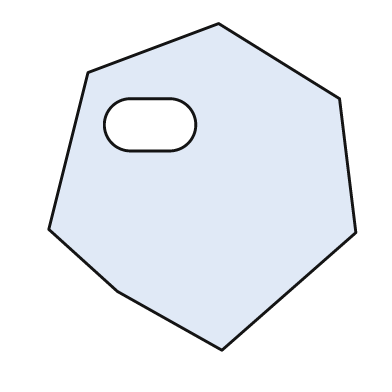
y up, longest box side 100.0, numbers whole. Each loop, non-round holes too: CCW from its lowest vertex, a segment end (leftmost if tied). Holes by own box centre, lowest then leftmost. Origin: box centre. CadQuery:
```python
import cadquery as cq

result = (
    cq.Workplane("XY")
    .moveTo(6.0, -50.0)
    .lineTo(47.0, -14.0)
    .lineTo(42.0, 27.0)
    .lineTo(5.0, 50.0)
    .lineTo(-35.0, 35.0)
    .lineTo(-47.0, -13.0)
    .lineTo(-26.0, -32.0)
    .close()
    .moveTo(-22.0, 11.0)
    .lineTo(-10.0, 11.0)
    .threePointArc((-2.0, 19.0), (-10.0, 27.0))
    .lineTo(-22.0, 27.0)
    .threePointArc((-30.0, 19.0), (-22.0, 11.0))
    .close()
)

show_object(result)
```